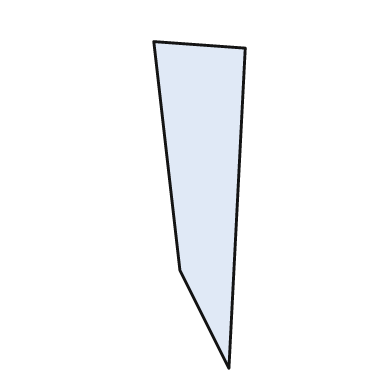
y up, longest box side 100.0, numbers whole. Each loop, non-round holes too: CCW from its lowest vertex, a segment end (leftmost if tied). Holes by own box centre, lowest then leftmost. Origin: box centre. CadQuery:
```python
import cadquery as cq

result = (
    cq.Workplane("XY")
    .moveTo(9.0, -50.0)
    .lineTo(14.0, 48.0)
    .lineTo(-14.0, 50.0)
    .lineTo(-6.0, -20.0)
    .close()
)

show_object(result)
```